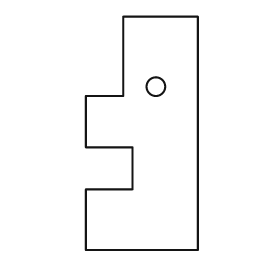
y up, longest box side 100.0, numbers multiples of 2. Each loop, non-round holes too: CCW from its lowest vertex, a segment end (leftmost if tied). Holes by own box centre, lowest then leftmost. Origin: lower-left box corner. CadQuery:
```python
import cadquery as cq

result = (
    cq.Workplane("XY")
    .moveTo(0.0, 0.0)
    .lineTo(48.0, 0.0)
    .lineTo(48.0, 100.0)
    .lineTo(16.0, 100.0)
    .lineTo(16.0, 66.0)
    .lineTo(0.0, 66.0)
    .lineTo(0.0, 44.0)
    .lineTo(20.0, 44.0)
    .lineTo(20.0, 26.0)
    .lineTo(0.0, 26.0)
    .close()
    .moveTo(30.0, 70.0)
    .circle(4.0)
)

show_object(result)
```